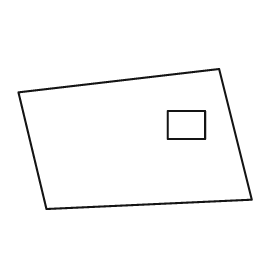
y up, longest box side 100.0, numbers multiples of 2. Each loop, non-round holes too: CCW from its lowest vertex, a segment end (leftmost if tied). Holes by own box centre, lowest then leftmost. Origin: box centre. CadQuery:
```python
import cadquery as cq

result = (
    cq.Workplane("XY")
    .moveTo(-38.0, -30.0)
    .lineTo(50.0, -26.0)
    .lineTo(36.0, 30.0)
    .lineTo(-50.0, 20.0)
    .close()
    .moveTo(14.0, 0.0)
    .lineTo(30.0, 0.0)
    .lineTo(30.0, 12.0)
    .lineTo(14.0, 12.0)
    .close()
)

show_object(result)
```